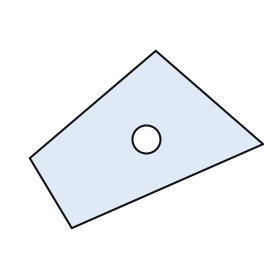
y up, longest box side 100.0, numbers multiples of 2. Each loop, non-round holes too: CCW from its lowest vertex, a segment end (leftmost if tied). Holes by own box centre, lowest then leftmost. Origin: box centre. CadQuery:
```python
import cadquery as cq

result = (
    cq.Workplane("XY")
    .moveTo(-32.0, -38.0)
    .lineTo(50.0, -2.0)
    .lineTo(4.0, 38.0)
    .lineTo(-50.0, -8.0)
    .close()
    .moveTo(0.0, 0.0)
    .circle(6.0)
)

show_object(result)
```